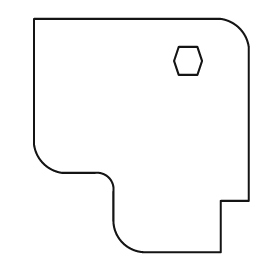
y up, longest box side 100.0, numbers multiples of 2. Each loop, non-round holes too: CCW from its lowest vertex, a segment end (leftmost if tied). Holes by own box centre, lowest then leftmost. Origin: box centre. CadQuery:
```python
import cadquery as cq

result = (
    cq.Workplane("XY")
    .moveTo(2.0, -50.0)
    .lineTo(34.0, -50.0)
    .lineTo(34.0, -28.0)
    .lineTo(46.0, -28.0)
    .lineTo(46.0, 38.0)
    .threePointArc((42.0, 46.0), (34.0, 50.0))
    .lineTo(-46.0, 50.0)
    .lineTo(-46.0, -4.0)
    .threePointArc((-42.0, -12.0), (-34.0, -16.0))
    .lineTo(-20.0, -16.0)
    .threePointArc((-14.0, -18.0), (-12.0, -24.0))
    .lineTo(-12.0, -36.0)
    .threePointArc((-8.0, -46.0), (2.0, -50.0))
    .close()
    .moveTo(16.0, 26.0)
    .lineTo(24.0, 26.0)
    .lineTo(26.0, 32.0)
    .lineTo(24.0, 38.0)
    .lineTo(16.0, 38.0)
    .lineTo(14.0, 32.0)
    .close()
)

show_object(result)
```